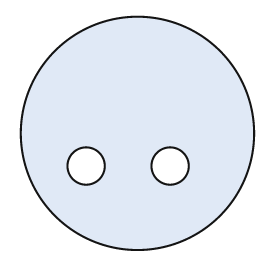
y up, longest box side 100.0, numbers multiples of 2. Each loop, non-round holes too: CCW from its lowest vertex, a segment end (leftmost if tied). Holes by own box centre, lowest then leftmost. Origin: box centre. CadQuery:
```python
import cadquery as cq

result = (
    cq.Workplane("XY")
    .moveTo(0.0, 0.0)
    .circle(50.0)
    .moveTo(-22.0, -14.0)
    .circle(8.0)
    .moveTo(14.0, -14.0)
    .circle(8.0)
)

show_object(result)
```